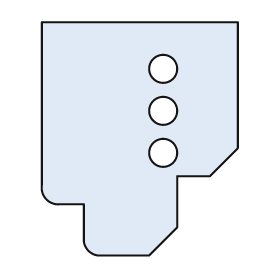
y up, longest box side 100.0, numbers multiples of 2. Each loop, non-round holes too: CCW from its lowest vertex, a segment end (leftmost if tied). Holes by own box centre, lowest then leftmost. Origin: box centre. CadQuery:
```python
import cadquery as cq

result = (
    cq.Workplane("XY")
    .moveTo(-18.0, -50.0)
    .lineTo(4.0, -50.0)
    .lineTo(16.0, -38.0)
    .lineTo(16.0, -16.0)
    .lineTo(30.0, -16.0)
    .lineTo(42.0, -4.0)
    .lineTo(42.0, 50.0)
    .lineTo(-42.0, 50.0)
    .lineTo(-42.0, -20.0)
    .threePointArc((-40.0, -26.0), (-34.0, -28.0))
    .lineTo(-24.0, -28.0)
    .lineTo(-24.0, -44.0)
    .threePointArc((-22.0, -48.0), (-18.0, -50.0))
    .close()
    .moveTo(10.0, -6.0)
    .circle(6.0)
    .moveTo(10.0, 12.0)
    .circle(6.0)
    .moveTo(10.0, 30.0)
    .circle(6.0)
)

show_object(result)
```